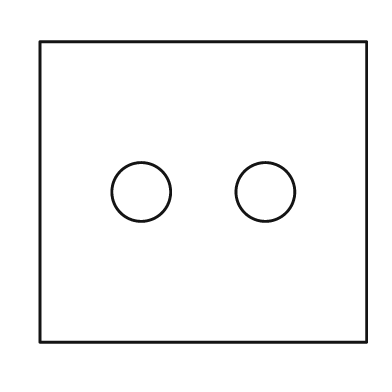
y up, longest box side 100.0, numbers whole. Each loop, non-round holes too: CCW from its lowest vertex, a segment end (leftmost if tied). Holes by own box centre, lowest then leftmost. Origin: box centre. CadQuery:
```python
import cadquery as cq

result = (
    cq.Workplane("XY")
    .moveTo(-50.0, -46.0)
    .lineTo(50.0, -46.0)
    .lineTo(50.0, 46.0)
    .lineTo(-50.0, 46.0)
    .close()
    .moveTo(-19.0, 0.0)
    .circle(9.0)
    .moveTo(19.0, 0.0)
    .circle(9.0)
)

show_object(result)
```